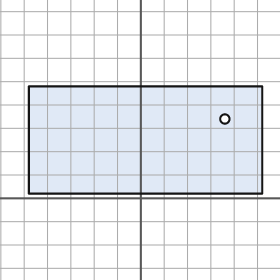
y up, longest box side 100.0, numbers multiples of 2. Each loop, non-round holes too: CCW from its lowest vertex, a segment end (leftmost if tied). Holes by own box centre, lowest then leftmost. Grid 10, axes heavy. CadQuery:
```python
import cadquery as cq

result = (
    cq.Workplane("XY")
    .moveTo(-48.0, 2.0)
    .lineTo(52.0, 2.0)
    .lineTo(52.0, 48.0)
    .lineTo(-48.0, 48.0)
    .close()
    .moveTo(36.0, 34.0)
    .circle(2.0)
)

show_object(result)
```